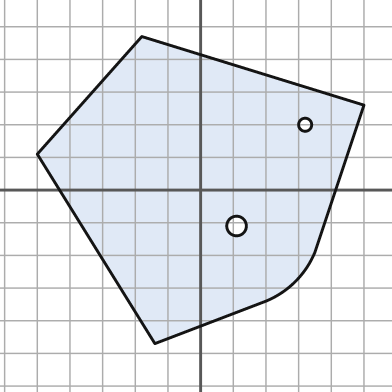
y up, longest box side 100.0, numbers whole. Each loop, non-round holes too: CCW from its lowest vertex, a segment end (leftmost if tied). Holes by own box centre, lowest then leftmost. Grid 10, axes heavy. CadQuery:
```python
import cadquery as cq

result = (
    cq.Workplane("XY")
    .moveTo(-14.0, -47.0)
    .lineTo(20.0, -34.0)
    .threePointArc((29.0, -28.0), (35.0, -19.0))
    .lineTo(50.0, 26.0)
    .lineTo(-18.0, 47.0)
    .lineTo(-50.0, 11.0)
    .close()
    .moveTo(11.0, -11.0)
    .circle(3.0)
    .moveTo(32.0, 20.0)
    .circle(2.0)
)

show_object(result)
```